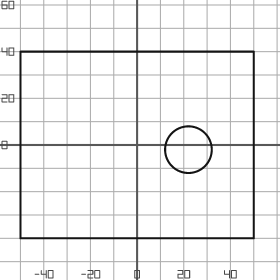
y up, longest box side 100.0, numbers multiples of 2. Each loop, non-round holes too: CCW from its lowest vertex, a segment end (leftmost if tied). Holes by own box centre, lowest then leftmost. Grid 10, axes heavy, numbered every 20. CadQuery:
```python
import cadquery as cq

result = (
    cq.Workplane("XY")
    .moveTo(-50.0, -40.0)
    .lineTo(50.0, -40.0)
    .lineTo(50.0, 40.0)
    .lineTo(-50.0, 40.0)
    .close()
    .moveTo(22.0, -2.0)
    .circle(10.0)
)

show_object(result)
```